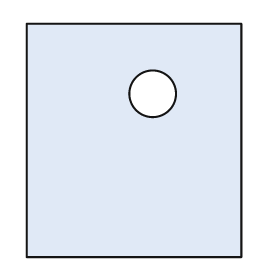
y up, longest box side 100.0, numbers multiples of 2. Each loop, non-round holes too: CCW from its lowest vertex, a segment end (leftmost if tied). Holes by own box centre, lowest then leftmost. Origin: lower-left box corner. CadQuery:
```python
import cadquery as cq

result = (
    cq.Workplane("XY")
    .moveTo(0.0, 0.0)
    .lineTo(92.0, 0.0)
    .lineTo(92.0, 100.0)
    .lineTo(0.0, 100.0)
    .close()
    .moveTo(54.0, 70.0)
    .circle(10.0)
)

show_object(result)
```